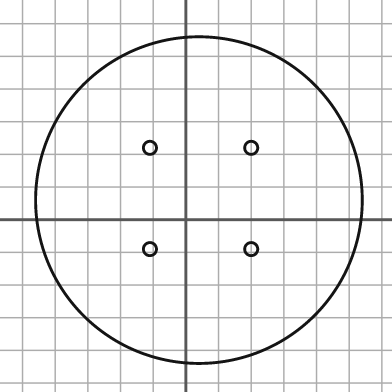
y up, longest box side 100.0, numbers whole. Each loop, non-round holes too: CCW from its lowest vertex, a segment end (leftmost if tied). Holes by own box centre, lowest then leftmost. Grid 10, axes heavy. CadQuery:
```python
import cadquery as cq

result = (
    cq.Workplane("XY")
    .moveTo(4.0, 6.0)
    .circle(50.0)
    .moveTo(-11.0, -9.0)
    .circle(2.0)
    .moveTo(20.0, -9.0)
    .circle(2.0)
    .moveTo(-11.0, 22.0)
    .circle(2.0)
    .moveTo(20.0, 22.0)
    .circle(2.0)
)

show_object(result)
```